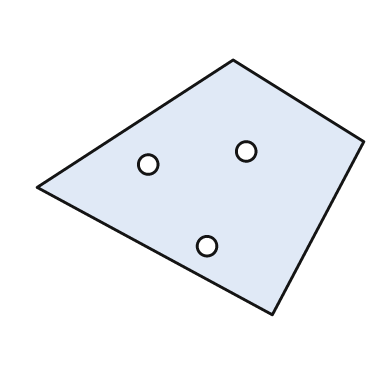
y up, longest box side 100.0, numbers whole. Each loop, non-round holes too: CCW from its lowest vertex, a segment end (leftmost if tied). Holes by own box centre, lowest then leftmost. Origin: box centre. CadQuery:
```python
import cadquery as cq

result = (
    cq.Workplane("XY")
    .moveTo(22.0, -39.0)
    .lineTo(50.0, 14.0)
    .lineTo(10.0, 39.0)
    .lineTo(-50.0, 0.0)
    .close()
    .moveTo(2.0, -18.0)
    .circle(3.0)
    .moveTo(-16.0, 7.0)
    .circle(3.0)
    .moveTo(14.0, 11.0)
    .circle(3.0)
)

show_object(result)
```